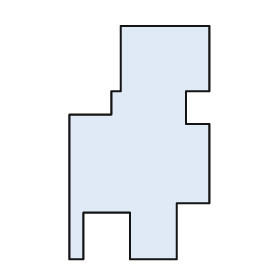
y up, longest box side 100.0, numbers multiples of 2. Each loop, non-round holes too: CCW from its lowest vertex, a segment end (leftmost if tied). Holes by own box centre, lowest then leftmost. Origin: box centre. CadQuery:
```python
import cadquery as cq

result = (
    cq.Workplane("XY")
    .moveTo(-30.0, -50.0)
    .lineTo(-24.0, -50.0)
    .lineTo(-24.0, -30.0)
    .lineTo(-4.0, -30.0)
    .lineTo(-4.0, -50.0)
    .lineTo(16.0, -50.0)
    .lineTo(16.0, -26.0)
    .lineTo(30.0, -26.0)
    .lineTo(30.0, 8.0)
    .lineTo(20.0, 8.0)
    .lineTo(20.0, 22.0)
    .lineTo(30.0, 22.0)
    .lineTo(30.0, 50.0)
    .lineTo(-8.0, 50.0)
    .lineTo(-8.0, 22.0)
    .lineTo(-12.0, 22.0)
    .lineTo(-12.0, 12.0)
    .lineTo(-30.0, 12.0)
    .close()
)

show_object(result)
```